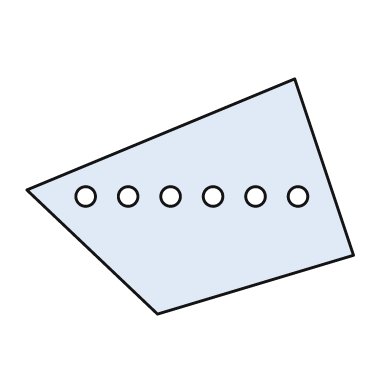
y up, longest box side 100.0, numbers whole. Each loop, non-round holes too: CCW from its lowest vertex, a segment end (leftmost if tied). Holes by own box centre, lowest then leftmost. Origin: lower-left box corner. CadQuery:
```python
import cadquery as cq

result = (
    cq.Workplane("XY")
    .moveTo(40.0, 0.0)
    .lineTo(100.0, 18.0)
    .lineTo(82.0, 72.0)
    .lineTo(0.0, 38.0)
    .close()
    .moveTo(18.0, 36.0)
    .circle(3.0)
    .moveTo(31.0, 36.0)
    .circle(3.0)
    .moveTo(44.0, 36.0)
    .circle(3.0)
    .moveTo(57.0, 36.0)
    .circle(3.0)
    .moveTo(70.0, 36.0)
    .circle(3.0)
    .moveTo(83.0, 36.0)
    .circle(3.0)
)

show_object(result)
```